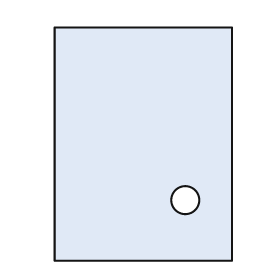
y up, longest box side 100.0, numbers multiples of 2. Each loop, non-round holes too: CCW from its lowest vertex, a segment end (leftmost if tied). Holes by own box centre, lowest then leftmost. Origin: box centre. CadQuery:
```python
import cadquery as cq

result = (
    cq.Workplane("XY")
    .moveTo(-38.0, -50.0)
    .lineTo(38.0, -50.0)
    .lineTo(38.0, 50.0)
    .lineTo(-38.0, 50.0)
    .close()
    .moveTo(18.0, -24.0)
    .circle(6.0)
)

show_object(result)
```